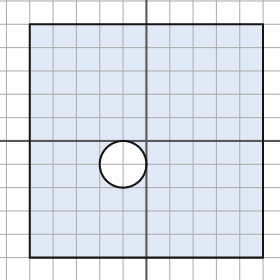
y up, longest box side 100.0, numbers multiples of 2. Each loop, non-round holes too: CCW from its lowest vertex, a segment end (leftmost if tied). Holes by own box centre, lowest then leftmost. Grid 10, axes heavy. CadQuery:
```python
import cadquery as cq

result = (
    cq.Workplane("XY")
    .moveTo(-50.0, -50.0)
    .lineTo(50.0, -50.0)
    .lineTo(50.0, 50.0)
    .lineTo(-50.0, 50.0)
    .close()
    .moveTo(-10.0, -10.0)
    .circle(10.0)
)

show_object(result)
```